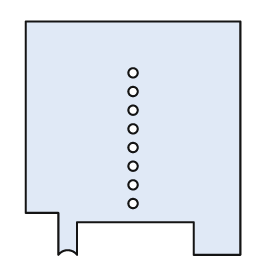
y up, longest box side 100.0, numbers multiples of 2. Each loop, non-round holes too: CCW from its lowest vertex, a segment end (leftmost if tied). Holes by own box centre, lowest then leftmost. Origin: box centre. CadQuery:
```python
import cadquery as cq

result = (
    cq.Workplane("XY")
    .moveTo(-32.0, -50.0)
    .threePointArc((-28.0, -48.0), (-24.0, -50.0))
    .lineTo(-24.0, -36.0)
    .lineTo(26.0, -36.0)
    .lineTo(26.0, -50.0)
    .lineTo(46.0, -50.0)
    .lineTo(46.0, 50.0)
    .lineTo(-46.0, 50.0)
    .lineTo(-46.0, -32.0)
    .lineTo(-32.0, -32.0)
    .close()
    .moveTo(0.0, -28.0)
    .circle(2.0)
    .moveTo(0.0, -20.0)
    .circle(2.0)
    .moveTo(0.0, -12.0)
    .circle(2.0)
    .moveTo(0.0, -4.0)
    .circle(2.0)
    .moveTo(0.0, 4.0)
    .circle(2.0)
    .moveTo(0.0, 12.0)
    .circle(2.0)
    .moveTo(0.0, 20.0)
    .circle(2.0)
    .moveTo(0.0, 28.0)
    .circle(2.0)
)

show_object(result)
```